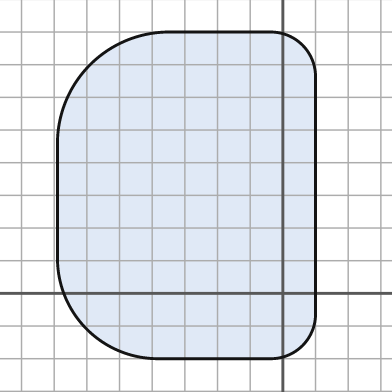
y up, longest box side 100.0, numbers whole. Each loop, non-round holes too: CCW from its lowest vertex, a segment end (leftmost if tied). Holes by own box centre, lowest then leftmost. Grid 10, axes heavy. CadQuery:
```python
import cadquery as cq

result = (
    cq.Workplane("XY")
    .moveTo(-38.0, -20.0)
    .lineTo(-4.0, -20.0)
    .threePointArc((6.0, -16.0), (10.0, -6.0))
    .lineTo(10.0, 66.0)
    .threePointArc((6.0, 76.0), (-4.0, 80.0))
    .lineTo(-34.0, 80.0)
    .threePointArc((-59.0, 70.0), (-69.0, 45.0))
    .lineTo(-69.0, 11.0)
    .threePointArc((-60.0, -11.0), (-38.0, -20.0))
    .close()
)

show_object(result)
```